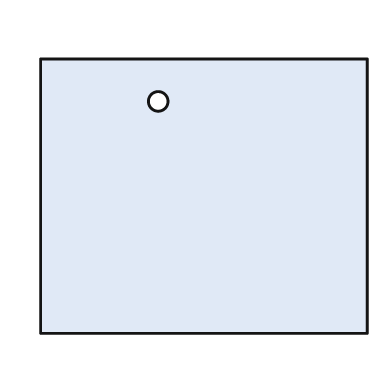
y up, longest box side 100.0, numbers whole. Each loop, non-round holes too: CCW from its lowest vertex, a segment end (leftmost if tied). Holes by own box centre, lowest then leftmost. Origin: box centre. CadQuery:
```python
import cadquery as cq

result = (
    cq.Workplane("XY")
    .moveTo(-50.0, -42.0)
    .lineTo(50.0, -42.0)
    .lineTo(50.0, 42.0)
    .lineTo(-50.0, 42.0)
    .close()
    .moveTo(-14.0, 29.0)
    .circle(3.0)
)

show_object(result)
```